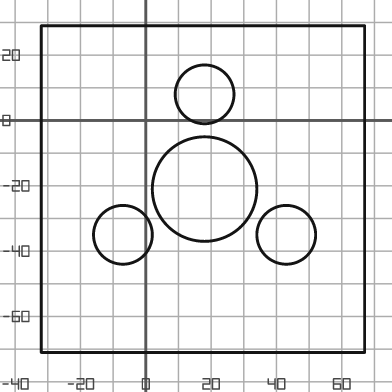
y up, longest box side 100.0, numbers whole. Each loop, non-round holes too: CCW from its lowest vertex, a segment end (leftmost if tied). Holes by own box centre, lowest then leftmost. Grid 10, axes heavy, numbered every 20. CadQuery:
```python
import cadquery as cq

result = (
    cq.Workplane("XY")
    .moveTo(-32.0, -71.0)
    .lineTo(67.0, -71.0)
    .lineTo(67.0, 29.0)
    .lineTo(-32.0, 29.0)
    .close()
    .moveTo(-7.0, -35.0)
    .circle(9.0)
    .moveTo(43.0, -35.0)
    .circle(9.0)
    .moveTo(18.0, -21.0)
    .circle(16.0)
    .moveTo(18.0, 8.0)
    .circle(9.0)
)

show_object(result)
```